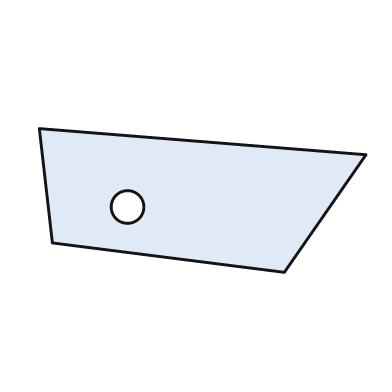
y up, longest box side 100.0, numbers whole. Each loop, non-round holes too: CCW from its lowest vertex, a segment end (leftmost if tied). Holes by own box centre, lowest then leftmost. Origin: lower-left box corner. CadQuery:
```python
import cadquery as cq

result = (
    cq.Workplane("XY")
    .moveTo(75.0, 0.0)
    .lineTo(100.0, 36.0)
    .lineTo(0.0, 44.0)
    .lineTo(4.0, 9.0)
    .close()
    .moveTo(27.0, 20.0)
    .circle(5.0)
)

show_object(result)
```